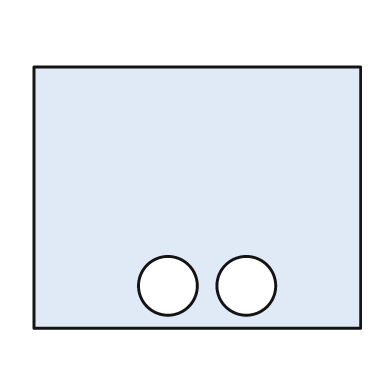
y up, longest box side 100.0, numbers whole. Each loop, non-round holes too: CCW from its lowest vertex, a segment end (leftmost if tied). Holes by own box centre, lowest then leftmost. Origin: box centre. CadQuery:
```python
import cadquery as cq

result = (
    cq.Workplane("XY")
    .moveTo(-50.0, -40.0)
    .lineTo(50.0, -40.0)
    .lineTo(50.0, 40.0)
    .lineTo(-50.0, 40.0)
    .close()
    .moveTo(-9.0, -27.0)
    .circle(9.0)
    .moveTo(15.0, -27.0)
    .circle(9.0)
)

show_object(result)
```